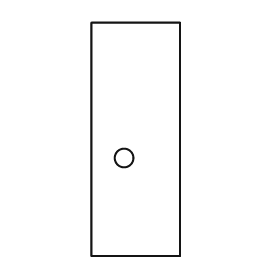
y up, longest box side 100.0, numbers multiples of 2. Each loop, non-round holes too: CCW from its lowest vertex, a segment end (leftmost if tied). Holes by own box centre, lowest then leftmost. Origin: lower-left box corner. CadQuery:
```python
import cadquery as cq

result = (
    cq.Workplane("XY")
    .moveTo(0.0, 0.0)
    .lineTo(38.0, 0.0)
    .lineTo(38.0, 100.0)
    .lineTo(0.0, 100.0)
    .close()
    .moveTo(14.0, 42.0)
    .circle(4.0)
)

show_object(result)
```